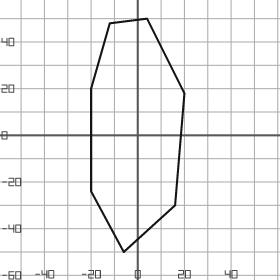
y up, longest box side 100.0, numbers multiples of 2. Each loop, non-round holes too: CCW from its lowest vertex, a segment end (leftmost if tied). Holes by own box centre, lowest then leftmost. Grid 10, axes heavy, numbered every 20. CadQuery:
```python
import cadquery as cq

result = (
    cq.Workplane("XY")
    .moveTo(-6.0, -50.0)
    .lineTo(16.0, -30.0)
    .lineTo(20.0, 18.0)
    .lineTo(4.0, 50.0)
    .lineTo(-12.0, 48.0)
    .lineTo(-20.0, 20.0)
    .lineTo(-20.0, -24.0)
    .close()
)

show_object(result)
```